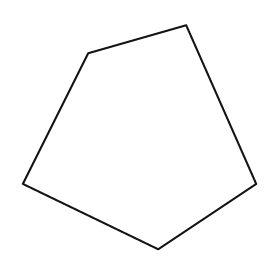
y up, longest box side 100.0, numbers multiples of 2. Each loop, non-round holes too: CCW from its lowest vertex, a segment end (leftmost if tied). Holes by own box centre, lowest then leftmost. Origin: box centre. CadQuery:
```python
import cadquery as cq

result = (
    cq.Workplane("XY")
    .moveTo(8.0, -48.0)
    .lineTo(50.0, -20.0)
    .lineTo(20.0, 48.0)
    .lineTo(-22.0, 36.0)
    .lineTo(-50.0, -20.0)
    .close()
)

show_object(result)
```